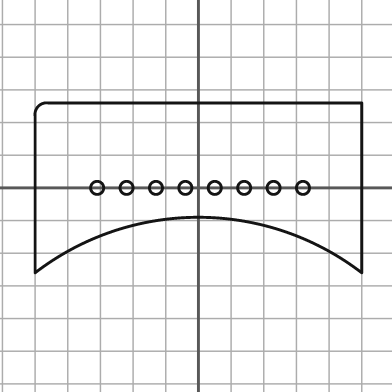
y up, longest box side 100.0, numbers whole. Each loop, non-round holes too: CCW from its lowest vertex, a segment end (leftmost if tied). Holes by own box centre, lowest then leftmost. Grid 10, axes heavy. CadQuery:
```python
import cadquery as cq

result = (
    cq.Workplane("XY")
    .moveTo(-50.0, -26.0)
    .threePointArc((0.0, -9.0), (50.0, -26.0))
    .lineTo(50.0, 26.0)
    .lineTo(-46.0, 26.0)
    .threePointArc((-49.0, 25.0), (-50.0, 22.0))
    .close()
    .moveTo(-31.0, 0.0)
    .circle(2.0)
    .moveTo(-22.0, 0.0)
    .circle(2.0)
    .moveTo(-13.0, 0.0)
    .circle(2.0)
    .moveTo(-4.0, 0.0)
    .circle(2.0)
    .moveTo(5.0, 0.0)
    .circle(2.0)
    .moveTo(14.0, 0.0)
    .circle(2.0)
    .moveTo(23.0, 0.0)
    .circle(2.0)
    .moveTo(32.0, 0.0)
    .circle(2.0)
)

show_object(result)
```